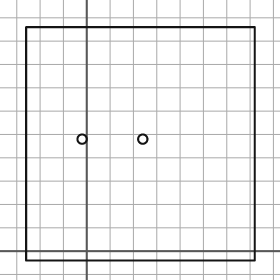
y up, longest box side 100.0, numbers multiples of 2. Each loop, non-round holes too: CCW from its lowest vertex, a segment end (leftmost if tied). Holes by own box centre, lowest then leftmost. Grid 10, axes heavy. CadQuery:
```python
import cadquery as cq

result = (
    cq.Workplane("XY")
    .moveTo(-26.0, -4.0)
    .lineTo(72.0, -4.0)
    .lineTo(72.0, 96.0)
    .lineTo(-26.0, 96.0)
    .close()
    .moveTo(-2.0, 48.0)
    .circle(2.0)
    .moveTo(24.0, 48.0)
    .circle(2.0)
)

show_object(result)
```